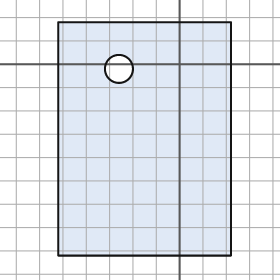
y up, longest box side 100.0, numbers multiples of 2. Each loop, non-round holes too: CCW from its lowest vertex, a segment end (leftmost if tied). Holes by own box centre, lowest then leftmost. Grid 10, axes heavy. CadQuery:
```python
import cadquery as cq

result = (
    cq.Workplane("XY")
    .moveTo(-52.0, -82.0)
    .lineTo(22.0, -82.0)
    .lineTo(22.0, 18.0)
    .lineTo(-52.0, 18.0)
    .close()
    .moveTo(-26.0, -2.0)
    .circle(6.0)
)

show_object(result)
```